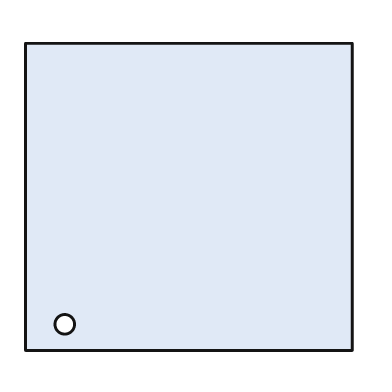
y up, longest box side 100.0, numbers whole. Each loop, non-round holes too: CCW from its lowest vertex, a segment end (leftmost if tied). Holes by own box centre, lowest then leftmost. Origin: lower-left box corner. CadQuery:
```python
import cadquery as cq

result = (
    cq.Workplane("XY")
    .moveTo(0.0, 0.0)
    .lineTo(100.0, 0.0)
    .lineTo(100.0, 94.0)
    .lineTo(0.0, 94.0)
    .close()
    .moveTo(12.0, 8.0)
    .circle(3.0)
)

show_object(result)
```